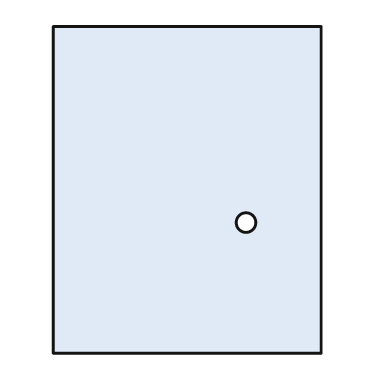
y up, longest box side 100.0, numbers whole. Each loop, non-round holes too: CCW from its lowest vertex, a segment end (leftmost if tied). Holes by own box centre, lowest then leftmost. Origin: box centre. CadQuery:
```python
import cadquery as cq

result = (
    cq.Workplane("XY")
    .moveTo(-41.0, -50.0)
    .lineTo(41.0, -50.0)
    .lineTo(41.0, 50.0)
    .lineTo(-41.0, 50.0)
    .close()
    .moveTo(18.0, -10.0)
    .circle(3.0)
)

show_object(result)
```